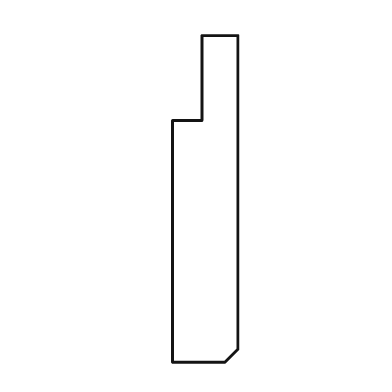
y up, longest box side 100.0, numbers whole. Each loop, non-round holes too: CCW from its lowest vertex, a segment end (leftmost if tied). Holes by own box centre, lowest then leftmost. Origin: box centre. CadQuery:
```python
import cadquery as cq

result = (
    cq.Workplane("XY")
    .moveTo(-10.0, -50.0)
    .lineTo(6.0, -50.0)
    .lineTo(10.0, -46.0)
    .lineTo(10.0, 50.0)
    .lineTo(-1.0, 50.0)
    .lineTo(-1.0, 24.0)
    .lineTo(-10.0, 24.0)
    .close()
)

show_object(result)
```